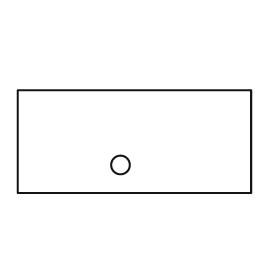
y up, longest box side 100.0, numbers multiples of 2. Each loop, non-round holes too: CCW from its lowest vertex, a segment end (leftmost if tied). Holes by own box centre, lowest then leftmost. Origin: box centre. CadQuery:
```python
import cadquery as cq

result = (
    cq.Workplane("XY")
    .moveTo(-50.0, -22.0)
    .lineTo(50.0, -22.0)
    .lineTo(50.0, 22.0)
    .lineTo(-50.0, 22.0)
    .close()
    .moveTo(-6.0, -10.0)
    .circle(4.0)
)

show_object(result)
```